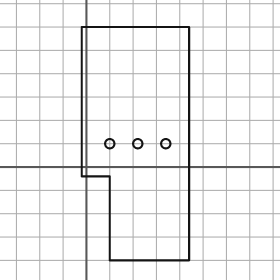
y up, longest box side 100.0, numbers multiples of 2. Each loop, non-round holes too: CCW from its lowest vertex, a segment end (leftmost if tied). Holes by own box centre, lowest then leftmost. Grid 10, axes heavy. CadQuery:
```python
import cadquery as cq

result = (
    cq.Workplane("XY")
    .moveTo(10.0, -40.0)
    .lineTo(44.0, -40.0)
    .lineTo(44.0, 60.0)
    .lineTo(-2.0, 60.0)
    .lineTo(-2.0, -4.0)
    .lineTo(10.0, -4.0)
    .close()
    .moveTo(10.0, 10.0)
    .circle(2.0)
    .moveTo(22.0, 10.0)
    .circle(2.0)
    .moveTo(34.0, 10.0)
    .circle(2.0)
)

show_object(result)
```